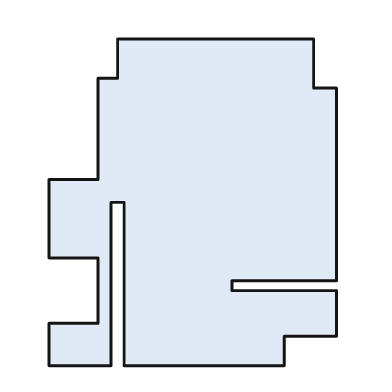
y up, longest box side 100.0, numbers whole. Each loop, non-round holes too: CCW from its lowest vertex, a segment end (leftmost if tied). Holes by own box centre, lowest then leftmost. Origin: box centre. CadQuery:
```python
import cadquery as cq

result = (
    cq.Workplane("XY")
    .moveTo(-44.0, -50.0)
    .lineTo(-25.0, -50.0)
    .lineTo(-25.0, 0.0)
    .lineTo(-21.0, 0.0)
    .lineTo(-21.0, -50.0)
    .lineTo(28.0, -50.0)
    .lineTo(28.0, -41.0)
    .lineTo(44.0, -41.0)
    .lineTo(44.0, -27.0)
    .lineTo(12.0, -27.0)
    .lineTo(12.0, -24.0)
    .lineTo(44.0, -24.0)
    .lineTo(44.0, 35.0)
    .lineTo(37.0, 35.0)
    .lineTo(37.0, 50.0)
    .lineTo(-23.0, 50.0)
    .lineTo(-23.0, 38.0)
    .lineTo(-29.0, 38.0)
    .lineTo(-29.0, 7.0)
    .lineTo(-44.0, 7.0)
    .lineTo(-44.0, -17.0)
    .lineTo(-29.0, -17.0)
    .lineTo(-29.0, -37.0)
    .lineTo(-44.0, -37.0)
    .close()
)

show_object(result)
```